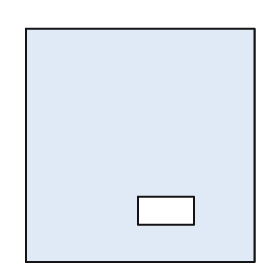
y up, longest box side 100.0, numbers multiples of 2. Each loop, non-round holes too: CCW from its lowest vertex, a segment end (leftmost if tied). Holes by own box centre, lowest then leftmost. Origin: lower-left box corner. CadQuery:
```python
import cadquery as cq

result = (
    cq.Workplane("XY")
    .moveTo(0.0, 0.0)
    .lineTo(98.0, 0.0)
    .lineTo(98.0, 100.0)
    .lineTo(0.0, 100.0)
    .close()
    .moveTo(48.0, 16.0)
    .lineTo(72.0, 16.0)
    .lineTo(72.0, 28.0)
    .lineTo(48.0, 28.0)
    .close()
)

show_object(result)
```